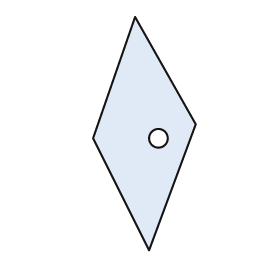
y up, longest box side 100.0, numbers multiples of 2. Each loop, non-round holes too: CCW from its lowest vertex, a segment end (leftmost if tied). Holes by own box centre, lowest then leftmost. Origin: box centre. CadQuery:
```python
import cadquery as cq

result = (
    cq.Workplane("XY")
    .moveTo(2.0, -50.0)
    .lineTo(22.0, 4.0)
    .lineTo(-4.0, 50.0)
    .lineTo(-22.0, -2.0)
    .close()
    .moveTo(6.0, -2.0)
    .circle(4.0)
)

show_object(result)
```